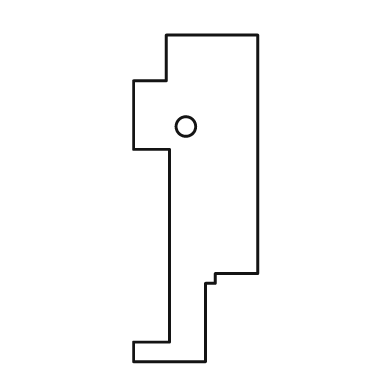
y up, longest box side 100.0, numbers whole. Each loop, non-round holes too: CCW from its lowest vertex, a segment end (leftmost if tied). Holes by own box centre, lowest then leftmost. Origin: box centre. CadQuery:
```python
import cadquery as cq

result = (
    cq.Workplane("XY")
    .moveTo(-19.0, -50.0)
    .lineTo(3.0, -50.0)
    .lineTo(3.0, -26.0)
    .lineTo(6.0, -26.0)
    .lineTo(6.0, -23.0)
    .lineTo(19.0, -23.0)
    .lineTo(19.0, 50.0)
    .lineTo(-9.0, 50.0)
    .lineTo(-9.0, 36.0)
    .lineTo(-19.0, 36.0)
    .lineTo(-19.0, 15.0)
    .lineTo(-8.0, 15.0)
    .lineTo(-8.0, -44.0)
    .lineTo(-19.0, -44.0)
    .close()
    .moveTo(-3.0, 22.0)
    .circle(3.0)
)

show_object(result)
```